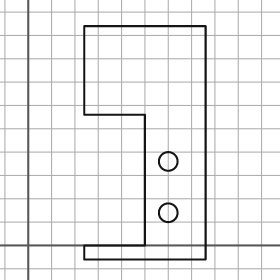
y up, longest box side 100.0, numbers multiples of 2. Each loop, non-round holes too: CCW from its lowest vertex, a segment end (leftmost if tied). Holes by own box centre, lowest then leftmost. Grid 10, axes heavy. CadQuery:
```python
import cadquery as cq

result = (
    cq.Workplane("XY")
    .moveTo(24.0, -6.0)
    .lineTo(76.0, -6.0)
    .lineTo(76.0, 94.0)
    .lineTo(24.0, 94.0)
    .lineTo(24.0, 56.0)
    .lineTo(50.0, 56.0)
    .lineTo(50.0, 0.0)
    .lineTo(24.0, 0.0)
    .close()
    .moveTo(60.0, 14.0)
    .circle(4.0)
    .moveTo(60.0, 36.0)
    .circle(4.0)
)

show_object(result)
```